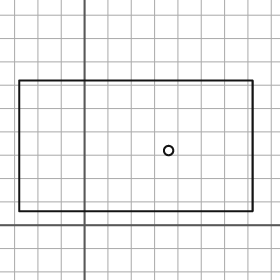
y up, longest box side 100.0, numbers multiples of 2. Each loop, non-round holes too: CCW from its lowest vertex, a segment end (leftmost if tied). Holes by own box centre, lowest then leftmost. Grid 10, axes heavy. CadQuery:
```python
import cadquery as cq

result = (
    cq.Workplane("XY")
    .moveTo(-28.0, 6.0)
    .lineTo(72.0, 6.0)
    .lineTo(72.0, 62.0)
    .lineTo(-28.0, 62.0)
    .close()
    .moveTo(36.0, 32.0)
    .circle(2.0)
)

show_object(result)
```